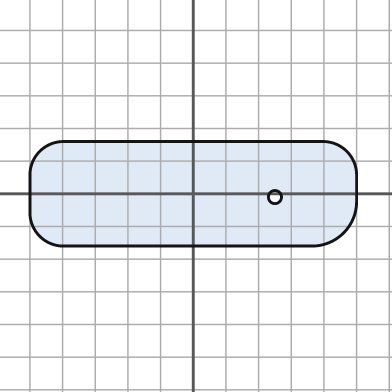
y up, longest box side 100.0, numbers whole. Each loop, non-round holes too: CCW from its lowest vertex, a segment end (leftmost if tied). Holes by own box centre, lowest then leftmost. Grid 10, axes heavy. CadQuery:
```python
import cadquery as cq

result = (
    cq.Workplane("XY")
    .moveTo(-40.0, -16.0)
    .lineTo(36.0, -16.0)
    .threePointArc((46.0, -12.0), (50.0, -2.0))
    .lineTo(50.0, 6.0)
    .threePointArc((47.0, 13.0), (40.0, 16.0))
    .lineTo(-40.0, 16.0)
    .threePointArc((-47.0, 13.0), (-50.0, 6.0))
    .lineTo(-50.0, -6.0)
    .threePointArc((-47.0, -13.0), (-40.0, -16.0))
    .close()
    .moveTo(25.0, -1.0)
    .circle(2.0)
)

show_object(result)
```